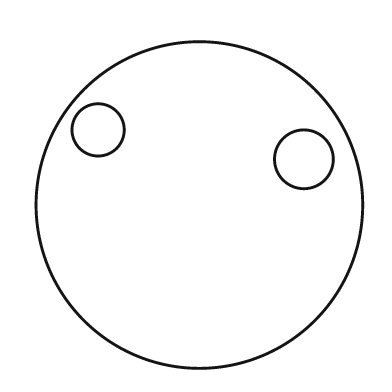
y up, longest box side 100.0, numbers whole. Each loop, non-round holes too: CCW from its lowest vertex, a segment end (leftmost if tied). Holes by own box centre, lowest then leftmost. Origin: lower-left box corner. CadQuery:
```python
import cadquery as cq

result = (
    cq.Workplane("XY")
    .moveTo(50.0, 50.0)
    .circle(50.0)
    .moveTo(82.0, 64.0)
    .circle(9.0)
    .moveTo(19.0, 73.0)
    .circle(8.0)
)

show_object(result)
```